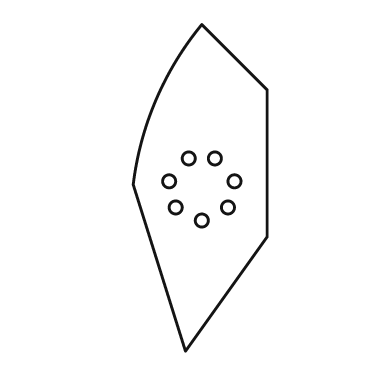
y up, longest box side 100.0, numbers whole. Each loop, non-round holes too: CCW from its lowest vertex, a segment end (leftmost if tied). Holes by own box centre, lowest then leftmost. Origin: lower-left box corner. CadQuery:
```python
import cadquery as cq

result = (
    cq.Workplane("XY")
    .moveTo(16.0, 0.0)
    .lineTo(41.0, 35.0)
    .lineTo(41.0, 80.0)
    .lineTo(21.0, 100.0)
    .threePointArc((7.0, 77.0), (0.0, 51.0))
    .close()
    .moveTo(21.0, 40.0)
    .circle(2.0)
    .moveTo(13.0, 44.0)
    .circle(2.0)
    .moveTo(29.0, 44.0)
    .circle(2.0)
    .moveTo(11.0, 52.0)
    .circle(2.0)
    .moveTo(31.0, 52.0)
    .circle(2.0)
    .moveTo(17.0, 59.0)
    .circle(2.0)
    .moveTo(25.0, 59.0)
    .circle(2.0)
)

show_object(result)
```